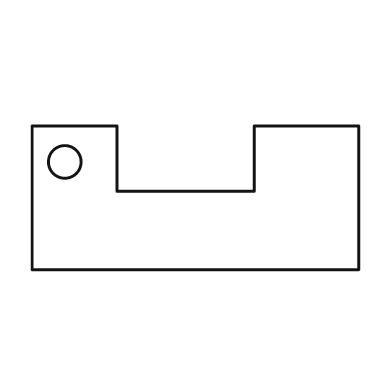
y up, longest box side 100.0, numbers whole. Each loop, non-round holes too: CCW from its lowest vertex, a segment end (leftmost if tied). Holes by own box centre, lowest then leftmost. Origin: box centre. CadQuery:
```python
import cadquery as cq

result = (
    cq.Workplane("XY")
    .moveTo(-50.0, -22.0)
    .lineTo(50.0, -22.0)
    .lineTo(50.0, 22.0)
    .lineTo(18.0, 22.0)
    .lineTo(18.0, 2.0)
    .lineTo(-24.0, 2.0)
    .lineTo(-24.0, 22.0)
    .lineTo(-50.0, 22.0)
    .close()
    .moveTo(-40.0, 11.0)
    .circle(5.0)
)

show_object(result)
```